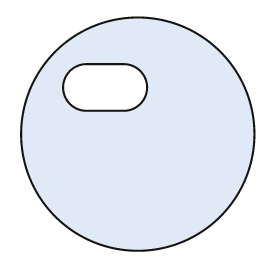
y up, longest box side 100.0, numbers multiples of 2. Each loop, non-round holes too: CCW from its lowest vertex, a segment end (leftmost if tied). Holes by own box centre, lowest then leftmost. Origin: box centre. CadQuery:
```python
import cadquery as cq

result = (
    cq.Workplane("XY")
    .moveTo(0.0, 0.0)
    .circle(50.0)
    .moveTo(-22.0, 10.0)
    .lineTo(-6.0, 10.0)
    .threePointArc((4.0, 20.0), (-6.0, 30.0))
    .lineTo(-22.0, 30.0)
    .threePointArc((-32.0, 20.0), (-22.0, 10.0))
    .close()
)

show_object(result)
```